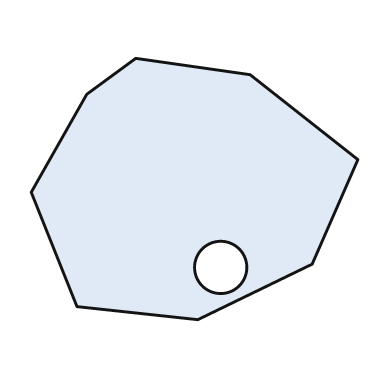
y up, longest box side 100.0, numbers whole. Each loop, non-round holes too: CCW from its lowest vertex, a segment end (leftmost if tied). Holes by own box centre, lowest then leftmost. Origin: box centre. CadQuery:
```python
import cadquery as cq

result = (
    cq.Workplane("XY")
    .moveTo(1.0, -40.0)
    .lineTo(36.0, -23.0)
    .lineTo(50.0, 9.0)
    .lineTo(17.0, 35.0)
    .lineTo(-18.0, 40.0)
    .lineTo(-33.0, 29.0)
    .lineTo(-50.0, -1.0)
    .lineTo(-36.0, -36.0)
    .close()
    .moveTo(8.0, -24.0)
    .circle(8.0)
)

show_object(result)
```